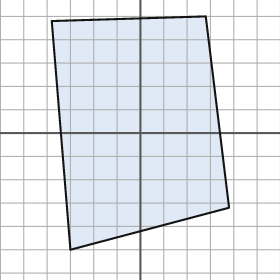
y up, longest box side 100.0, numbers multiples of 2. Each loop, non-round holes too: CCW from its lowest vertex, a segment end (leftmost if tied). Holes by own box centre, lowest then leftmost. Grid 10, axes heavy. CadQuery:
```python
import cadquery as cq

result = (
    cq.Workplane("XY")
    .moveTo(-30.0, -50.0)
    .lineTo(38.0, -32.0)
    .lineTo(28.0, 50.0)
    .lineTo(-38.0, 48.0)
    .close()
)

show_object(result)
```